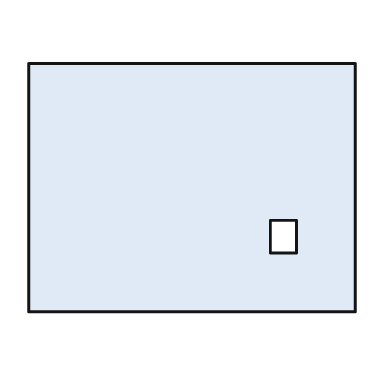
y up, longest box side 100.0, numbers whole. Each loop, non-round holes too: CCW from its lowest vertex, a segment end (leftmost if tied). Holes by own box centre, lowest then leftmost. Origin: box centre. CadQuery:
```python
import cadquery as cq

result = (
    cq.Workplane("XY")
    .moveTo(-50.0, -38.0)
    .lineTo(50.0, -38.0)
    .lineTo(50.0, 38.0)
    .lineTo(-50.0, 38.0)
    .close()
    .moveTo(24.0, -20.0)
    .lineTo(32.0, -20.0)
    .lineTo(32.0, -10.0)
    .lineTo(24.0, -10.0)
    .close()
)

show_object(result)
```